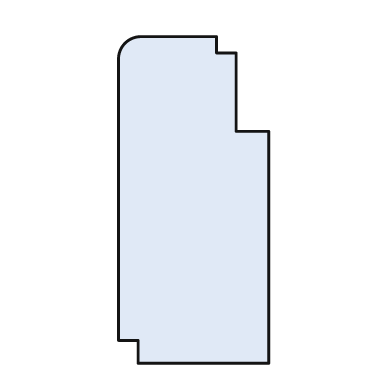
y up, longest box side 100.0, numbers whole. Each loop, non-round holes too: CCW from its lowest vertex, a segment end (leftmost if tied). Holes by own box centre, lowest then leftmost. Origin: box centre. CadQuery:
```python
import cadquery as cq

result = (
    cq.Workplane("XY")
    .moveTo(-17.0, -50.0)
    .lineTo(23.0, -50.0)
    .lineTo(23.0, 21.0)
    .lineTo(13.0, 21.0)
    .lineTo(13.0, 45.0)
    .lineTo(7.0, 45.0)
    .lineTo(7.0, 50.0)
    .lineTo(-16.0, 50.0)
    .threePointArc((-21.0, 48.0), (-23.0, 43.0))
    .lineTo(-23.0, -43.0)
    .lineTo(-17.0, -43.0)
    .close()
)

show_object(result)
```